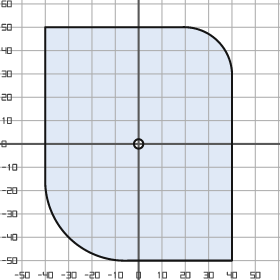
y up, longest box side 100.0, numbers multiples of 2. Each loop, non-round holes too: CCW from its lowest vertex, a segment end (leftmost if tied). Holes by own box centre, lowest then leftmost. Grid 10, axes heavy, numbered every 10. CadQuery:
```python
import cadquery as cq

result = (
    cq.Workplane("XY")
    .moveTo(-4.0, -50.0)
    .lineTo(40.0, -50.0)
    .lineTo(40.0, 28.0)
    .threePointArc((34.0, 44.0), (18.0, 50.0))
    .lineTo(-40.0, 50.0)
    .lineTo(-40.0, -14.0)
    .threePointArc((-30.0, -40.0), (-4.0, -50.0))
    .close()
    .moveTo(0.0, 0.0)
    .circle(2.0)
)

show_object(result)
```